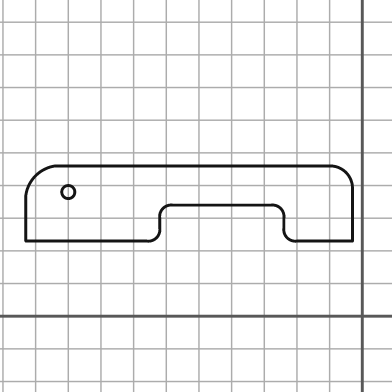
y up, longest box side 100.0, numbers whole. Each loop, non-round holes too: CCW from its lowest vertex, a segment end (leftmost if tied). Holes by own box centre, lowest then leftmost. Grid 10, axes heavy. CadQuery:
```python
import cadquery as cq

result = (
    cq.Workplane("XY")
    .moveTo(-103.0, 23.0)
    .lineTo(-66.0, 23.0)
    .threePointArc((-63.0, 24.0), (-62.0, 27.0))
    .lineTo(-62.0, 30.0)
    .threePointArc((-61.0, 33.0), (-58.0, 34.0))
    .lineTo(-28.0, 34.0)
    .threePointArc((-25.0, 33.0), (-24.0, 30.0))
    .lineTo(-24.0, 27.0)
    .threePointArc((-23.0, 24.0), (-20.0, 23.0))
    .lineTo(-3.0, 23.0)
    .lineTo(-3.0, 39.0)
    .threePointArc((-5.0, 44.0), (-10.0, 46.0))
    .lineTo(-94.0, 46.0)
    .threePointArc((-100.0, 43.0), (-103.0, 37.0))
    .close()
    .moveTo(-90.0, 38.0)
    .circle(2.0)
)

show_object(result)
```